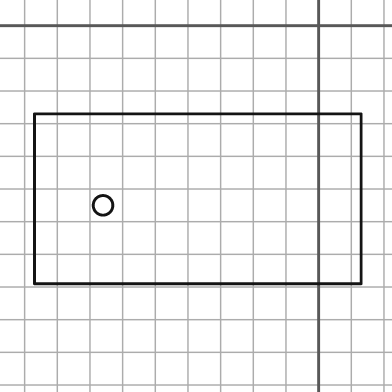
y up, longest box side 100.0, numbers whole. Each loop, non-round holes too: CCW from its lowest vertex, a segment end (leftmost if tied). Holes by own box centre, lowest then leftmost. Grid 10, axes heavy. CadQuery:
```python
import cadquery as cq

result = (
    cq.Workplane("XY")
    .moveTo(-87.0, -79.0)
    .lineTo(13.0, -79.0)
    .lineTo(13.0, -27.0)
    .lineTo(-87.0, -27.0)
    .close()
    .moveTo(-66.0, -55.0)
    .circle(3.0)
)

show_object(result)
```